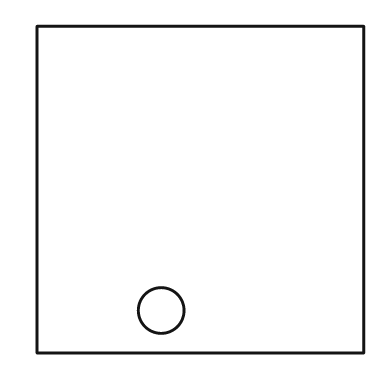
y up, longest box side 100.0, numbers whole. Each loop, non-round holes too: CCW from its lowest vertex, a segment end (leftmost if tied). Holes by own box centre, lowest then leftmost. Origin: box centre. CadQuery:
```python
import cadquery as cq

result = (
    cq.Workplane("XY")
    .moveTo(-50.0, -50.0)
    .lineTo(50.0, -50.0)
    .lineTo(50.0, 50.0)
    .lineTo(-50.0, 50.0)
    .close()
    .moveTo(-12.0, -37.0)
    .circle(7.0)
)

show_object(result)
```